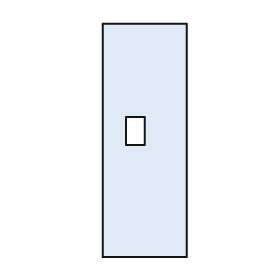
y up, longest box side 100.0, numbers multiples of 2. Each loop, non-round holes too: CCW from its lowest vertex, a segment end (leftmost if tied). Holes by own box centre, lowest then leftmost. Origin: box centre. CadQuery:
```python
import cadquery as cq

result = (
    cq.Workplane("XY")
    .moveTo(-18.0, -50.0)
    .lineTo(18.0, -50.0)
    .lineTo(18.0, 50.0)
    .lineTo(-18.0, 50.0)
    .close()
    .moveTo(-8.0, -2.0)
    .lineTo(0.0, -2.0)
    .lineTo(0.0, 10.0)
    .lineTo(-8.0, 10.0)
    .close()
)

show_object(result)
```